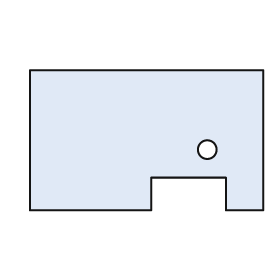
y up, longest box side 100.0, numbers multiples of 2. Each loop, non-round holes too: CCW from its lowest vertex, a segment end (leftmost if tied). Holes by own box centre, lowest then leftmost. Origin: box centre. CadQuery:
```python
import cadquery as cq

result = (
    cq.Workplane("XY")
    .moveTo(-50.0, -30.0)
    .lineTo(2.0, -30.0)
    .lineTo(2.0, -16.0)
    .lineTo(34.0, -16.0)
    .lineTo(34.0, -30.0)
    .lineTo(50.0, -30.0)
    .lineTo(50.0, 30.0)
    .lineTo(-50.0, 30.0)
    .close()
    .moveTo(26.0, -4.0)
    .circle(4.0)
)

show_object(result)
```